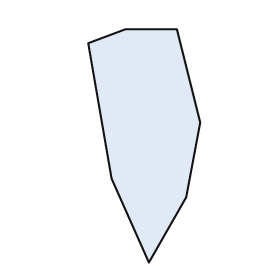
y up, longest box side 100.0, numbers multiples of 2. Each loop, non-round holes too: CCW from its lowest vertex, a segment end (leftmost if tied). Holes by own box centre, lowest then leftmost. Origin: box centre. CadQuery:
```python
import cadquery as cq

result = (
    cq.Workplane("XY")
    .moveTo(2.0, -50.0)
    .lineTo(18.0, -22.0)
    .lineTo(24.0, 10.0)
    .lineTo(14.0, 50.0)
    .lineTo(-8.0, 50.0)
    .lineTo(-24.0, 44.0)
    .lineTo(-14.0, -14.0)
    .close()
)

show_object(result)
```